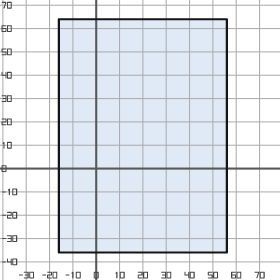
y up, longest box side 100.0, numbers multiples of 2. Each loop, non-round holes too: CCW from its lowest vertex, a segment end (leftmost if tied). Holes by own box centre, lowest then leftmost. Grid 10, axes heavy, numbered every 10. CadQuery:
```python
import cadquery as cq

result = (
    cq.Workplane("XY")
    .moveTo(-16.0, -36.0)
    .lineTo(56.0, -36.0)
    .lineTo(56.0, 64.0)
    .lineTo(-16.0, 64.0)
    .close()
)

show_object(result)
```